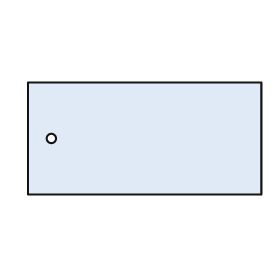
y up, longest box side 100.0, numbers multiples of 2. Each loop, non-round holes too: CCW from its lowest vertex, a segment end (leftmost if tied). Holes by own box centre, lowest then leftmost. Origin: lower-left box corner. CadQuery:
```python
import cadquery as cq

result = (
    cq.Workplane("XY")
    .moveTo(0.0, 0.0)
    .lineTo(100.0, 0.0)
    .lineTo(100.0, 48.0)
    .lineTo(0.0, 48.0)
    .close()
    .moveTo(10.0, 24.0)
    .circle(2.0)
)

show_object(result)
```